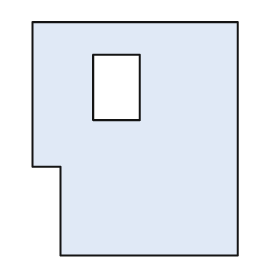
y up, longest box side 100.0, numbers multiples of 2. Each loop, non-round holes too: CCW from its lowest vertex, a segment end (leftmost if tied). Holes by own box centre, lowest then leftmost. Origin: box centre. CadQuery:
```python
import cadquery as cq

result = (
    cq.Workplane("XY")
    .moveTo(-32.0, -50.0)
    .lineTo(44.0, -50.0)
    .lineTo(44.0, 50.0)
    .lineTo(-44.0, 50.0)
    .lineTo(-44.0, -12.0)
    .lineTo(-32.0, -12.0)
    .close()
    .moveTo(-18.0, 8.0)
    .lineTo(2.0, 8.0)
    .lineTo(2.0, 36.0)
    .lineTo(-18.0, 36.0)
    .close()
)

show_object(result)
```